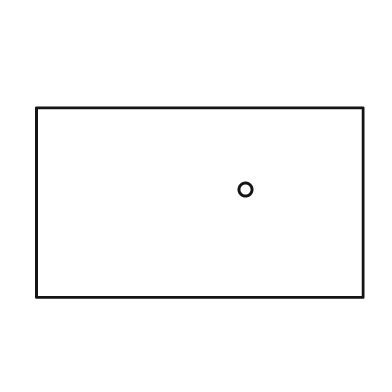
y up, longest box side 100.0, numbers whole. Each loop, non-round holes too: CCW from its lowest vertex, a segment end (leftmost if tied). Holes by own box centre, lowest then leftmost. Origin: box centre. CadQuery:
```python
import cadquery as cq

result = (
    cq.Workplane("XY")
    .moveTo(-50.0, -29.0)
    .lineTo(50.0, -29.0)
    .lineTo(50.0, 29.0)
    .lineTo(-50.0, 29.0)
    .close()
    .moveTo(14.0, 4.0)
    .circle(2.0)
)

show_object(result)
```